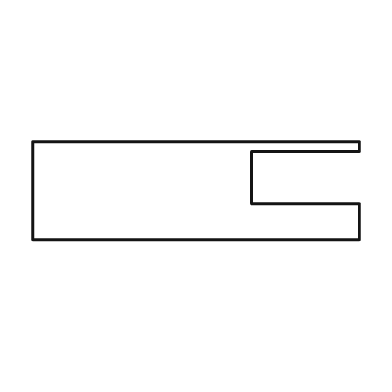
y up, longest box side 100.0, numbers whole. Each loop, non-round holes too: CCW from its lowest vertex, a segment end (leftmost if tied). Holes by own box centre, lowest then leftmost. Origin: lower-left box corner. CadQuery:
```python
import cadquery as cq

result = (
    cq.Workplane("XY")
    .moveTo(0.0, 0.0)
    .lineTo(100.0, 0.0)
    .lineTo(100.0, 11.0)
    .lineTo(67.0, 11.0)
    .lineTo(67.0, 27.0)
    .lineTo(100.0, 27.0)
    .lineTo(100.0, 30.0)
    .lineTo(0.0, 30.0)
    .close()
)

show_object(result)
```